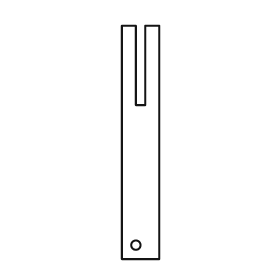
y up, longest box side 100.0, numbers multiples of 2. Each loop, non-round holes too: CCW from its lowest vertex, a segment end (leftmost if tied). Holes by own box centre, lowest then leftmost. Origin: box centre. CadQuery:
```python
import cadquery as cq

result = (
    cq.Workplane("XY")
    .moveTo(-8.0, -50.0)
    .lineTo(8.0, -50.0)
    .lineTo(8.0, 50.0)
    .lineTo(2.0, 50.0)
    .lineTo(2.0, 16.0)
    .lineTo(-2.0, 16.0)
    .lineTo(-2.0, 50.0)
    .lineTo(-8.0, 50.0)
    .close()
    .moveTo(-2.0, -44.0)
    .circle(2.0)
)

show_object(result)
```